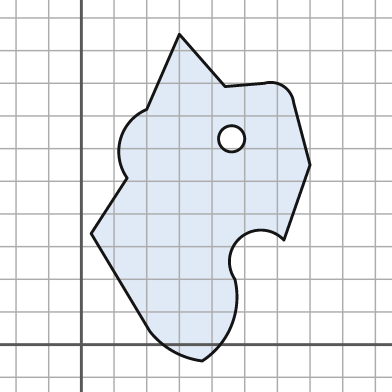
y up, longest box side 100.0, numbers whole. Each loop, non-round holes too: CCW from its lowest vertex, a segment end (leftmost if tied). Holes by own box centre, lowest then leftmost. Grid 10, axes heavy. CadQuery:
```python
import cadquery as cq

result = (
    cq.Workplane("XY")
    .moveTo(37.0, -5.0)
    .threePointArc((46.0, 6.0), (47.0, 20.0))
    .threePointArc((49.0, 33.0), (62.0, 32.0))
    .lineTo(70.0, 55.0)
    .lineTo(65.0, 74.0)
    .threePointArc((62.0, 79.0), (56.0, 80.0))
    .lineTo(44.0, 79.0)
    .lineTo(30.0, 95.0)
    .lineTo(20.0, 72.0)
    .threePointArc((12.0, 63.0), (14.0, 51.0))
    .lineTo(3.0, 34.0)
    .lineTo(21.0, 4.0)
    .threePointArc((28.0, -2.0), (37.0, -5.0))
    .close()
    .moveTo(46.0, 63.0)
    .circle(4.0)
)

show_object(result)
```